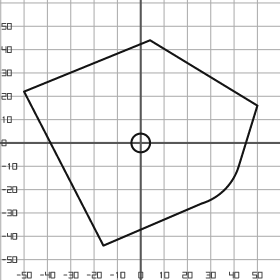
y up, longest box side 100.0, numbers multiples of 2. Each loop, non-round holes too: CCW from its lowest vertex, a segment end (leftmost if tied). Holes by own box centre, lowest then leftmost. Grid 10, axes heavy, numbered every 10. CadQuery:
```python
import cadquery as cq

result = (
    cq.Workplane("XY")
    .moveTo(-16.0, -44.0)
    .lineTo(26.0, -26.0)
    .threePointArc((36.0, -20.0), (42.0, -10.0))
    .lineTo(50.0, 16.0)
    .lineTo(4.0, 44.0)
    .lineTo(-50.0, 22.0)
    .close()
    .moveTo(0.0, 0.0)
    .circle(4.0)
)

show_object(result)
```